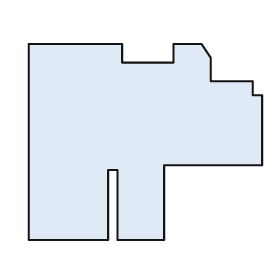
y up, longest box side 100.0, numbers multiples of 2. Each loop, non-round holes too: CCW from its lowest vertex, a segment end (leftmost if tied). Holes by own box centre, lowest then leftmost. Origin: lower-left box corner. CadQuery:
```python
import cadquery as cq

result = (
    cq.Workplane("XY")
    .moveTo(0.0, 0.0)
    .lineTo(34.0, 0.0)
    .lineTo(34.0, 30.0)
    .lineTo(38.0, 30.0)
    .lineTo(38.0, 0.0)
    .lineTo(58.0, 0.0)
    .lineTo(58.0, 32.0)
    .lineTo(100.0, 32.0)
    .lineTo(100.0, 62.0)
    .lineTo(96.0, 62.0)
    .lineTo(96.0, 68.0)
    .lineTo(78.0, 68.0)
    .lineTo(78.0, 78.0)
    .lineTo(74.0, 84.0)
    .lineTo(62.0, 84.0)
    .lineTo(62.0, 76.0)
    .lineTo(40.0, 76.0)
    .lineTo(40.0, 84.0)
    .lineTo(0.0, 84.0)
    .close()
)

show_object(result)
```